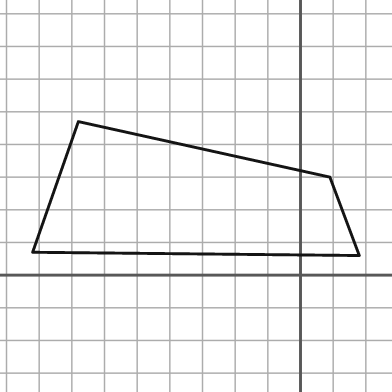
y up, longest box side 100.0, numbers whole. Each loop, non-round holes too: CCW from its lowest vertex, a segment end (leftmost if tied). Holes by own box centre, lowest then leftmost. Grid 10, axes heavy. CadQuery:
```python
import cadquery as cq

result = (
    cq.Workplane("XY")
    .moveTo(18.0, 6.0)
    .lineTo(9.0, 30.0)
    .lineTo(-68.0, 47.0)
    .lineTo(-82.0, 7.0)
    .close()
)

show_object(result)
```